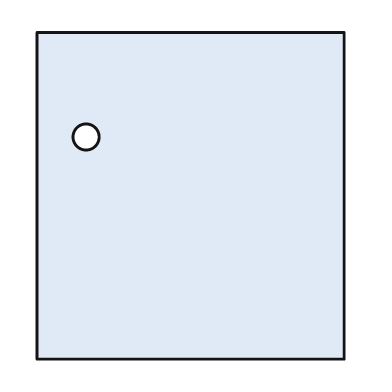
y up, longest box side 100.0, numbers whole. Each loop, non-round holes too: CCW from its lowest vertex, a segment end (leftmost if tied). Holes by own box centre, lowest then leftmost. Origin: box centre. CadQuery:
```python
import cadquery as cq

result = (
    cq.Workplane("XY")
    .moveTo(-47.0, -50.0)
    .lineTo(47.0, -50.0)
    .lineTo(47.0, 50.0)
    .lineTo(-47.0, 50.0)
    .close()
    .moveTo(-32.0, 18.0)
    .circle(4.0)
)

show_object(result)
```